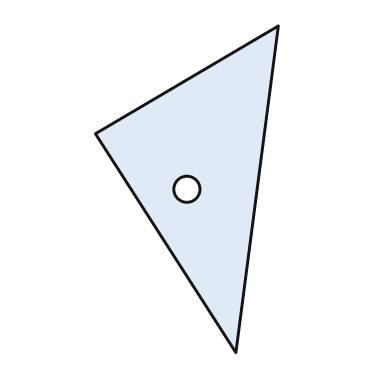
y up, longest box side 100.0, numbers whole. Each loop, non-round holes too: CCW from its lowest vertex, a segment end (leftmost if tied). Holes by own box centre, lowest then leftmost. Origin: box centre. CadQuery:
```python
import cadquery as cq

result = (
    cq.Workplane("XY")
    .moveTo(15.0, -50.0)
    .lineTo(28.0, 50.0)
    .lineTo(-28.0, 17.0)
    .close()
    .moveTo(0.0, 0.0)
    .circle(4.0)
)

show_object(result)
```